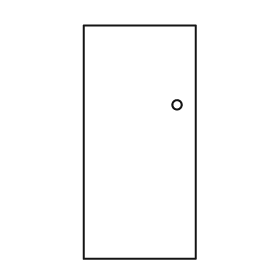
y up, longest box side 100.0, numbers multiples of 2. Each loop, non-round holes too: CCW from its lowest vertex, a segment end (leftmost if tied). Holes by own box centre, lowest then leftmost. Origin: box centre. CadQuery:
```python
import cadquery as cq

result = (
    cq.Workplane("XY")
    .moveTo(-24.0, -50.0)
    .lineTo(24.0, -50.0)
    .lineTo(24.0, 50.0)
    .lineTo(-24.0, 50.0)
    .close()
    .moveTo(16.0, 16.0)
    .circle(2.0)
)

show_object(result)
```